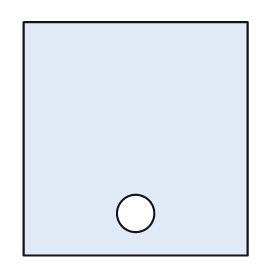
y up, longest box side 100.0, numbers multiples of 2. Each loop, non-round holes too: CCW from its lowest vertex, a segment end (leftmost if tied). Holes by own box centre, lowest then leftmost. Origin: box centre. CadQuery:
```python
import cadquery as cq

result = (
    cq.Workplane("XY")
    .moveTo(-48.0, -50.0)
    .lineTo(48.0, -50.0)
    .lineTo(48.0, 50.0)
    .lineTo(-48.0, 50.0)
    .close()
    .moveTo(0.0, -32.0)
    .circle(8.0)
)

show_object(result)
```